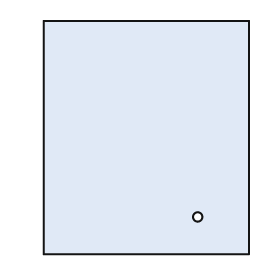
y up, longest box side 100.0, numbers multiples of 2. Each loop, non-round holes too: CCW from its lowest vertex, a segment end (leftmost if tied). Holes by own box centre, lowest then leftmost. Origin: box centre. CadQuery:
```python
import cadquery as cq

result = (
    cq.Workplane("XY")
    .moveTo(-44.0, -50.0)
    .lineTo(44.0, -50.0)
    .lineTo(44.0, 50.0)
    .lineTo(-44.0, 50.0)
    .close()
    .moveTo(22.0, -34.0)
    .circle(2.0)
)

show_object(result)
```